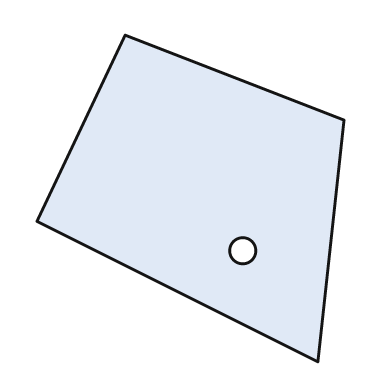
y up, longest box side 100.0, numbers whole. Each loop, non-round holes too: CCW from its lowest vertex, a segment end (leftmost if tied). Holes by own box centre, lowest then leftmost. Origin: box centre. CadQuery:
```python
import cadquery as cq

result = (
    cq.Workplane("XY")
    .moveTo(39.0, -50.0)
    .lineTo(47.0, 24.0)
    .lineTo(-20.0, 50.0)
    .lineTo(-47.0, -7.0)
    .close()
    .moveTo(16.0, -16.0)
    .circle(4.0)
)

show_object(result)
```